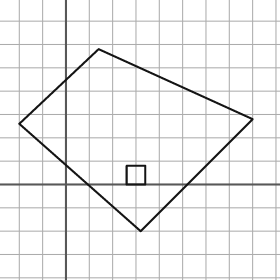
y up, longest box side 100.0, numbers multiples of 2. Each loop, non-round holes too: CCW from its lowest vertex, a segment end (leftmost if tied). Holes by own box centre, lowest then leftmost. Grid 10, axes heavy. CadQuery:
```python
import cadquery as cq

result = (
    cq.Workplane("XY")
    .moveTo(32.0, -20.0)
    .lineTo(80.0, 28.0)
    .lineTo(14.0, 58.0)
    .lineTo(-20.0, 26.0)
    .close()
    .moveTo(26.0, 0.0)
    .lineTo(34.0, 0.0)
    .lineTo(34.0, 8.0)
    .lineTo(26.0, 8.0)
    .close()
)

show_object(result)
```